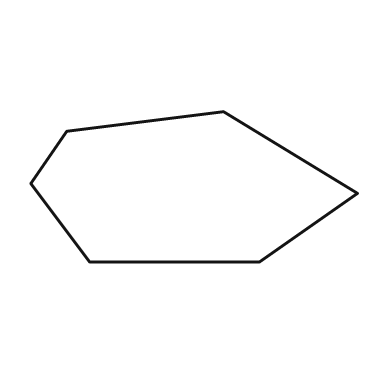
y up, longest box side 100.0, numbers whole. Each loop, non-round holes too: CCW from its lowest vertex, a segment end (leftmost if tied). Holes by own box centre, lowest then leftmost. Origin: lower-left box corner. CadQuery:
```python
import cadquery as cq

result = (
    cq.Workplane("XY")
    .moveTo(18.0, 0.0)
    .lineTo(70.0, 0.0)
    .lineTo(100.0, 21.0)
    .lineTo(59.0, 46.0)
    .lineTo(11.0, 40.0)
    .lineTo(0.0, 24.0)
    .close()
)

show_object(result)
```